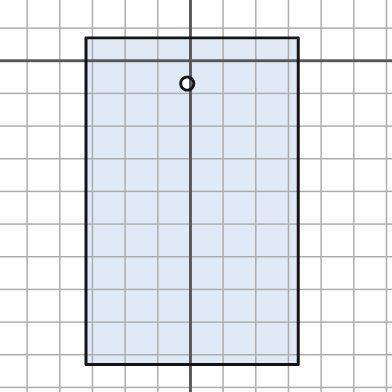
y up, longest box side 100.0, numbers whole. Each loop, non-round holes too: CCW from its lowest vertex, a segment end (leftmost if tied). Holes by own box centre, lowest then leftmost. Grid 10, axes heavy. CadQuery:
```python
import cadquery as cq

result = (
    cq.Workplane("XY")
    .moveTo(-32.0, -93.0)
    .lineTo(33.0, -93.0)
    .lineTo(33.0, 7.0)
    .lineTo(-32.0, 7.0)
    .close()
    .moveTo(-1.0, -7.0)
    .circle(2.0)
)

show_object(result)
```